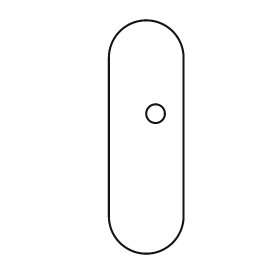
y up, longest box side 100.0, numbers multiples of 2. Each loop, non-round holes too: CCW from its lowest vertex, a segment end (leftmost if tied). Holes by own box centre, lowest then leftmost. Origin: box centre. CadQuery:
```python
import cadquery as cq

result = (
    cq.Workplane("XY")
    .moveTo(-16.0, -34.0)
    .threePointArc((0.0, -50.0), (16.0, -34.0))
    .lineTo(16.0, 34.0)
    .threePointArc((0.0, 50.0), (-16.0, 34.0))
    .close()
    .moveTo(4.0, 10.0)
    .circle(4.0)
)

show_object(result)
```